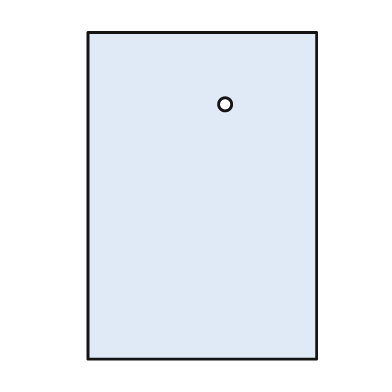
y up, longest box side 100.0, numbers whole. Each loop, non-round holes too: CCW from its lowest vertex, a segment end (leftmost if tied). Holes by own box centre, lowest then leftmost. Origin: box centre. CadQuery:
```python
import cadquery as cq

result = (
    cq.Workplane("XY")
    .moveTo(-35.0, -50.0)
    .lineTo(35.0, -50.0)
    .lineTo(35.0, 50.0)
    .lineTo(-35.0, 50.0)
    .close()
    .moveTo(7.0, 28.0)
    .circle(2.0)
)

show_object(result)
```